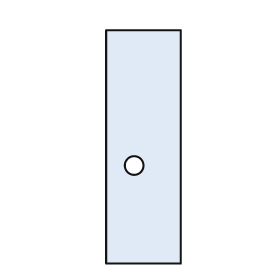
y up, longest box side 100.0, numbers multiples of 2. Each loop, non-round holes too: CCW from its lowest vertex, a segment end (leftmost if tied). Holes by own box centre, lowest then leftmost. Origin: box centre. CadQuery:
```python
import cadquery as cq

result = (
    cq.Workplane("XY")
    .moveTo(-16.0, -50.0)
    .lineTo(16.0, -50.0)
    .lineTo(16.0, 50.0)
    .lineTo(-16.0, 50.0)
    .close()
    .moveTo(-4.0, -8.0)
    .circle(4.0)
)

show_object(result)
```